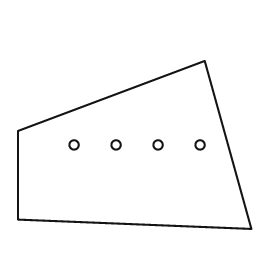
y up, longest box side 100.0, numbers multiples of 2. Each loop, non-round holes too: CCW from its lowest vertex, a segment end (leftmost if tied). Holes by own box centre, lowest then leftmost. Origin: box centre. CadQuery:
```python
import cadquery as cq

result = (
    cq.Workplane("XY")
    .moveTo(50.0, -36.0)
    .lineTo(30.0, 36.0)
    .lineTo(-50.0, 6.0)
    .lineTo(-50.0, -32.0)
    .close()
    .moveTo(-26.0, 0.0)
    .circle(2.0)
    .moveTo(-8.0, 0.0)
    .circle(2.0)
    .moveTo(10.0, 0.0)
    .circle(2.0)
    .moveTo(28.0, 0.0)
    .circle(2.0)
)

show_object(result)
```